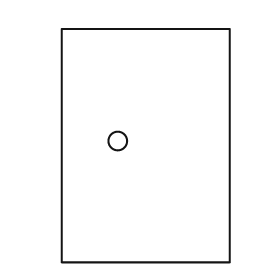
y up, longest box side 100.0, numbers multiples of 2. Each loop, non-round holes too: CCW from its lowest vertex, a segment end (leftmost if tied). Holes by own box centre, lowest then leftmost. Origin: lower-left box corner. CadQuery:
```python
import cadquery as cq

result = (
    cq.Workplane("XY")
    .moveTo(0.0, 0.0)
    .lineTo(72.0, 0.0)
    .lineTo(72.0, 100.0)
    .lineTo(0.0, 100.0)
    .close()
    .moveTo(24.0, 52.0)
    .circle(4.0)
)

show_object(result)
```